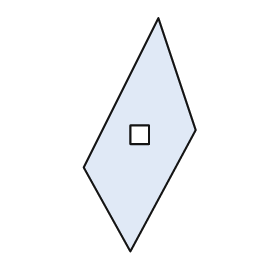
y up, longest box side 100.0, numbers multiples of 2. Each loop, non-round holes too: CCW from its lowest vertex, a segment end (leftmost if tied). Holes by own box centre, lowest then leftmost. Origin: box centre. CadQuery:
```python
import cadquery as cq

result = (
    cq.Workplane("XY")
    .moveTo(-4.0, -50.0)
    .lineTo(24.0, 2.0)
    .lineTo(8.0, 50.0)
    .lineTo(-24.0, -14.0)
    .close()
    .moveTo(-4.0, -4.0)
    .lineTo(4.0, -4.0)
    .lineTo(4.0, 4.0)
    .lineTo(-4.0, 4.0)
    .close()
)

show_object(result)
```